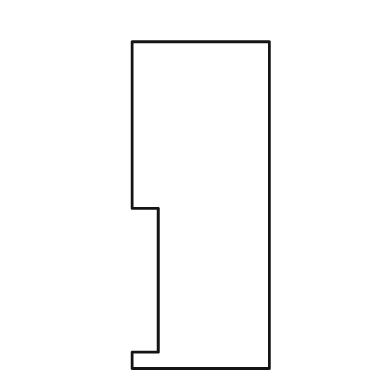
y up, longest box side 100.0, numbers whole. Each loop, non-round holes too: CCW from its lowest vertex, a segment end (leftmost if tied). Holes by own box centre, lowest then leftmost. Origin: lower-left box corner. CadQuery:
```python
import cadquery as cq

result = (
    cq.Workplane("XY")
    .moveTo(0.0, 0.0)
    .lineTo(42.0, 0.0)
    .lineTo(42.0, 100.0)
    .lineTo(0.0, 100.0)
    .lineTo(0.0, 49.0)
    .lineTo(8.0, 49.0)
    .lineTo(8.0, 5.0)
    .lineTo(0.0, 5.0)
    .close()
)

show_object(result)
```